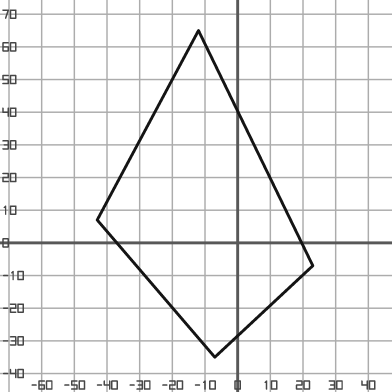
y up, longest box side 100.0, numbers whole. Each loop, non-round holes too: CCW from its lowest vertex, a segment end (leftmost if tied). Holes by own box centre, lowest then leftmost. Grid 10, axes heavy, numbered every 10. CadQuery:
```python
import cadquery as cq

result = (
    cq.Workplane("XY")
    .moveTo(-7.0, -35.0)
    .lineTo(23.0, -7.0)
    .lineTo(-12.0, 65.0)
    .lineTo(-43.0, 7.0)
    .close()
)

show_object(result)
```